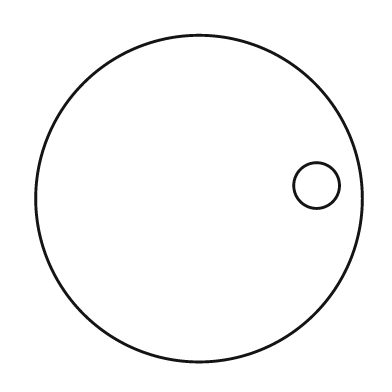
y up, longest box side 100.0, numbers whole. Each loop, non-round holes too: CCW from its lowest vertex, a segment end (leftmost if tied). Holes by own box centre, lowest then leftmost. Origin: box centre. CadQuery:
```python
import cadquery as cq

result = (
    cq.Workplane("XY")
    .moveTo(0.0, 0.0)
    .circle(50.0)
    .moveTo(36.0, 4.0)
    .circle(7.0)
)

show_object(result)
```